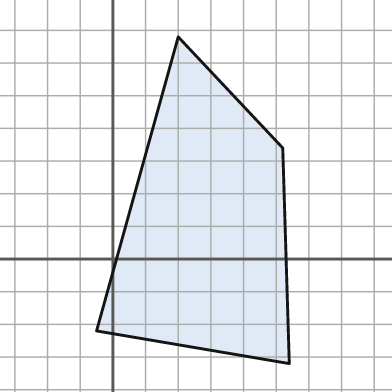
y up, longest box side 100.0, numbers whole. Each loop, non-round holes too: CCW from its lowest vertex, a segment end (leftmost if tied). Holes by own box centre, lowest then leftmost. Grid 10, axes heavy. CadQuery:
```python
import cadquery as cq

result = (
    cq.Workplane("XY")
    .moveTo(54.0, -32.0)
    .lineTo(52.0, 34.0)
    .lineTo(20.0, 68.0)
    .lineTo(-5.0, -22.0)
    .close()
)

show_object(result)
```